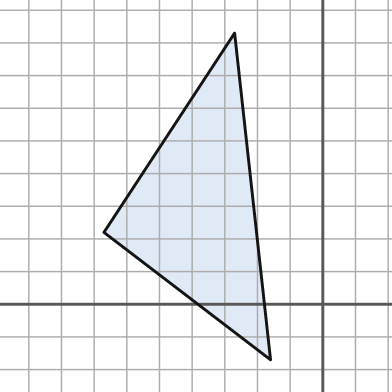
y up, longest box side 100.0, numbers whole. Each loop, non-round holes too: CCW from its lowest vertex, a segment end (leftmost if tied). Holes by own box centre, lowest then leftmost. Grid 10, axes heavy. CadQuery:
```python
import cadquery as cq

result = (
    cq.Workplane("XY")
    .moveTo(-16.0, -17.0)
    .lineTo(-27.0, 83.0)
    .lineTo(-67.0, 22.0)
    .close()
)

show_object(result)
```